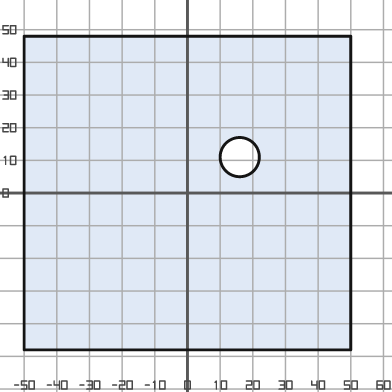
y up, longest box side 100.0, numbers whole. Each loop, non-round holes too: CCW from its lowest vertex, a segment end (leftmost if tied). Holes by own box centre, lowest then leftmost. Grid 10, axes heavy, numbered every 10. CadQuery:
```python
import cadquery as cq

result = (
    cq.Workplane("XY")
    .moveTo(-50.0, -48.0)
    .lineTo(50.0, -48.0)
    .lineTo(50.0, 48.0)
    .lineTo(-50.0, 48.0)
    .close()
    .moveTo(16.0, 11.0)
    .circle(6.0)
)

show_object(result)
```